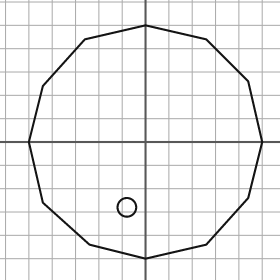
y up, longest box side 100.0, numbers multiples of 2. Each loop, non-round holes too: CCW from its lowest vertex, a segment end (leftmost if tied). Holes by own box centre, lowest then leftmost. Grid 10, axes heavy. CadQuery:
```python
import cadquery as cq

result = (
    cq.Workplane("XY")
    .moveTo(0.0, -50.0)
    .lineTo(26.0, -44.0)
    .lineTo(44.0, -24.0)
    .lineTo(50.0, 0.0)
    .lineTo(44.0, 26.0)
    .lineTo(26.0, 44.0)
    .lineTo(0.0, 50.0)
    .lineTo(-26.0, 44.0)
    .lineTo(-44.0, 24.0)
    .lineTo(-50.0, 0.0)
    .lineTo(-44.0, -26.0)
    .lineTo(-24.0, -44.0)
    .close()
    .moveTo(-8.0, -28.0)
    .circle(4.0)
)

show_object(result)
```